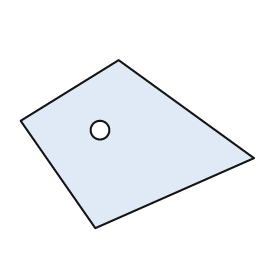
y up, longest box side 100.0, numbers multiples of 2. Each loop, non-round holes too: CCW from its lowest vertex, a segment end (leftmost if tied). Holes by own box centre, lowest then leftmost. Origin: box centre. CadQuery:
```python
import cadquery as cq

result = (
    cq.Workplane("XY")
    .moveTo(-18.0, -36.0)
    .lineTo(50.0, -6.0)
    .lineTo(-8.0, 36.0)
    .lineTo(-50.0, 10.0)
    .close()
    .moveTo(-16.0, 6.0)
    .circle(4.0)
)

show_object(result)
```